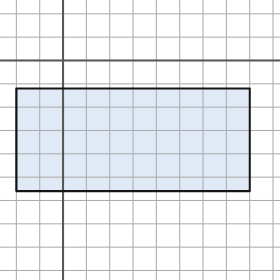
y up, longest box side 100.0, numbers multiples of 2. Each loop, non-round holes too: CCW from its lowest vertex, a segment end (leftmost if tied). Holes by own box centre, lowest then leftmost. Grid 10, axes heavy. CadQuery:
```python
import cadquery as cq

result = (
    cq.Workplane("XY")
    .moveTo(-20.0, -56.0)
    .lineTo(80.0, -56.0)
    .lineTo(80.0, -12.0)
    .lineTo(-20.0, -12.0)
    .close()
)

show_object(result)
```